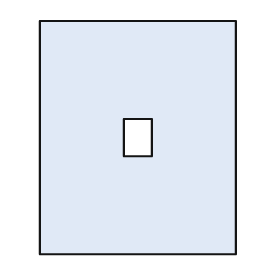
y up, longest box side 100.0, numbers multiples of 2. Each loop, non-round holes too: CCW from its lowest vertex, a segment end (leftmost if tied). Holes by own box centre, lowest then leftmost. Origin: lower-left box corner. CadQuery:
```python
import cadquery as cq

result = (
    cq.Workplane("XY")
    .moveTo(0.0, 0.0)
    .lineTo(84.0, 0.0)
    .lineTo(84.0, 100.0)
    .lineTo(0.0, 100.0)
    .close()
    .moveTo(36.0, 42.0)
    .lineTo(48.0, 42.0)
    .lineTo(48.0, 58.0)
    .lineTo(36.0, 58.0)
    .close()
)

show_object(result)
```